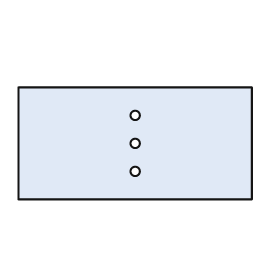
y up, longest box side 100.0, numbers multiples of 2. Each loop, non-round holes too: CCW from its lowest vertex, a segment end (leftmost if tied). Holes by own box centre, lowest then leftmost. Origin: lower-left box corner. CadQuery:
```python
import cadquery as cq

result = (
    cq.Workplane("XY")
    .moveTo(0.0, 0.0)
    .lineTo(100.0, 0.0)
    .lineTo(100.0, 48.0)
    .lineTo(0.0, 48.0)
    .close()
    .moveTo(50.0, 12.0)
    .circle(2.0)
    .moveTo(50.0, 24.0)
    .circle(2.0)
    .moveTo(50.0, 36.0)
    .circle(2.0)
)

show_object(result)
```